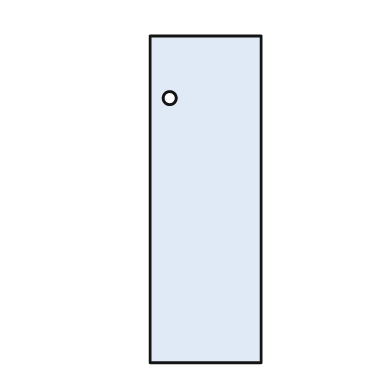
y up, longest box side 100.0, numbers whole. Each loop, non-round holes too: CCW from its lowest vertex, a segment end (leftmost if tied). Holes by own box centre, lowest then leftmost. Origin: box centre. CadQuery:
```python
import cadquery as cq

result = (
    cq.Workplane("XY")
    .moveTo(-17.0, -50.0)
    .lineTo(17.0, -50.0)
    .lineTo(17.0, 50.0)
    .lineTo(-17.0, 50.0)
    .close()
    .moveTo(-11.0, 31.0)
    .circle(2.0)
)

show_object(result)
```